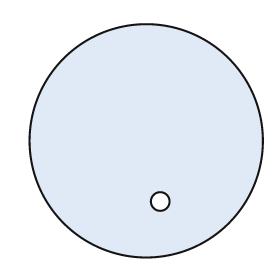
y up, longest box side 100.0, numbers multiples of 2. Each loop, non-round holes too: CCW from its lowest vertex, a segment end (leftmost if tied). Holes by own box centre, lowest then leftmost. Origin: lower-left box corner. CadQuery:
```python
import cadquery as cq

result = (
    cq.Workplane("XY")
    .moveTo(50.0, 50.0)
    .circle(50.0)
    .moveTo(56.0, 24.0)
    .circle(4.0)
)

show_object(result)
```